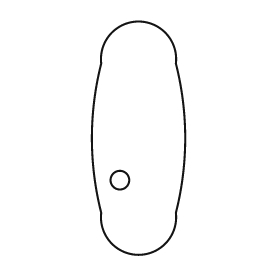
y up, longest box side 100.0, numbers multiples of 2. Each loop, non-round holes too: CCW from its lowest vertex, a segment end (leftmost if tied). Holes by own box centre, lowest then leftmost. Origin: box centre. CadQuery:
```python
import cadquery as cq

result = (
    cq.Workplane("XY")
    .moveTo(-16.0, -32.0)
    .threePointArc((0.0, -50.0), (16.0, -32.0))
    .threePointArc((20.0, 0.0), (16.0, 32.0))
    .threePointArc((0.0, 50.0), (-16.0, 32.0))
    .threePointArc((-20.0, 0.0), (-16.0, -32.0))
    .close()
    .moveTo(-8.0, -18.0)
    .circle(4.0)
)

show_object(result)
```